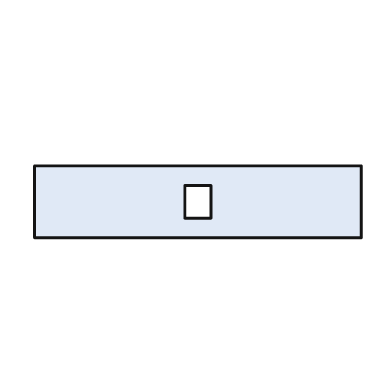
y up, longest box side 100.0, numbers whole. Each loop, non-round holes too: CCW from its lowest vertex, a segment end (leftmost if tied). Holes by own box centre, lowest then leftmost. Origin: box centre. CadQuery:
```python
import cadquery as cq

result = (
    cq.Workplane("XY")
    .moveTo(-50.0, -11.0)
    .lineTo(50.0, -11.0)
    .lineTo(50.0, 11.0)
    .lineTo(-50.0, 11.0)
    .close()
    .moveTo(-4.0, -5.0)
    .lineTo(4.0, -5.0)
    .lineTo(4.0, 5.0)
    .lineTo(-4.0, 5.0)
    .close()
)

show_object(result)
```